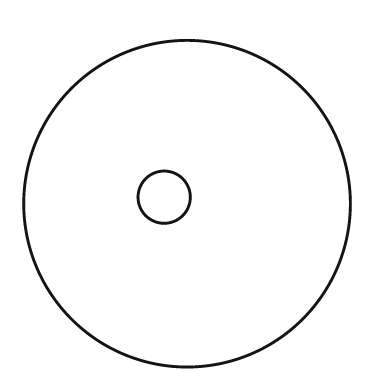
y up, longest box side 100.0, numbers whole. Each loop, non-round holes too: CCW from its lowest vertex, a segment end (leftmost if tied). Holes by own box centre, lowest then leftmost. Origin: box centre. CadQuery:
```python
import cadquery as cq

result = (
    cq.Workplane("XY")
    .moveTo(0.0, 0.0)
    .circle(50.0)
    .moveTo(-7.0, 2.0)
    .circle(8.0)
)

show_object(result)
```